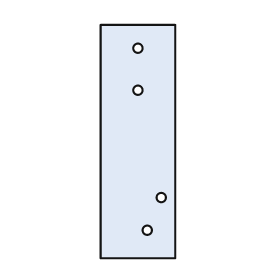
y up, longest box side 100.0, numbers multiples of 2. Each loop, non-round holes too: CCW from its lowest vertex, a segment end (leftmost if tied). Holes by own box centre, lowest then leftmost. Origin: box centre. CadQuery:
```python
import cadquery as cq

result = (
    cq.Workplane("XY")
    .moveTo(-16.0, -50.0)
    .lineTo(16.0, -50.0)
    .lineTo(16.0, 50.0)
    .lineTo(-16.0, 50.0)
    .close()
    .moveTo(4.0, -38.0)
    .circle(2.0)
    .moveTo(10.0, -24.0)
    .circle(2.0)
    .moveTo(0.0, 22.0)
    .circle(2.0)
    .moveTo(0.0, 40.0)
    .circle(2.0)
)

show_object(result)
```